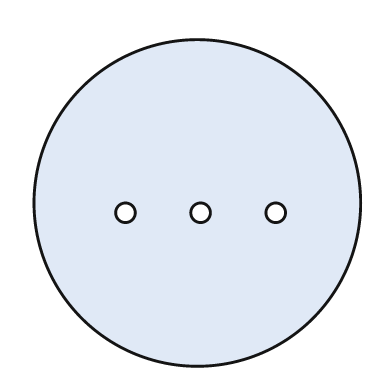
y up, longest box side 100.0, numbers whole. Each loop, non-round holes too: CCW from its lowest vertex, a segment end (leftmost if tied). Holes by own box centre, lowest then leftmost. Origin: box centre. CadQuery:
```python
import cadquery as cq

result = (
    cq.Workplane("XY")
    .moveTo(0.0, 0.0)
    .circle(50.0)
    .moveTo(-22.0, -3.0)
    .circle(3.0)
    .moveTo(1.0, -3.0)
    .circle(3.0)
    .moveTo(24.0, -3.0)
    .circle(3.0)
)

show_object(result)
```